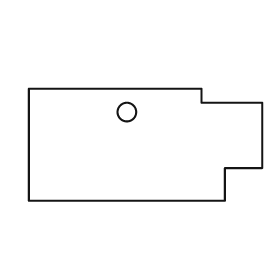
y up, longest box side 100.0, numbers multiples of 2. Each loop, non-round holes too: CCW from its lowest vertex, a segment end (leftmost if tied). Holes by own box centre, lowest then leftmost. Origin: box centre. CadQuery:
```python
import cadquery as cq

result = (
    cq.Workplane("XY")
    .moveTo(-50.0, -24.0)
    .lineTo(34.0, -24.0)
    .lineTo(34.0, -10.0)
    .lineTo(50.0, -10.0)
    .lineTo(50.0, 18.0)
    .lineTo(24.0, 18.0)
    .lineTo(24.0, 24.0)
    .lineTo(-50.0, 24.0)
    .close()
    .moveTo(-8.0, 14.0)
    .circle(4.0)
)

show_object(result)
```